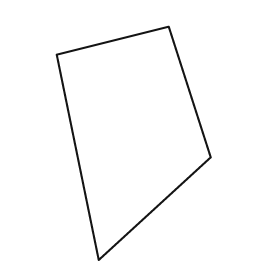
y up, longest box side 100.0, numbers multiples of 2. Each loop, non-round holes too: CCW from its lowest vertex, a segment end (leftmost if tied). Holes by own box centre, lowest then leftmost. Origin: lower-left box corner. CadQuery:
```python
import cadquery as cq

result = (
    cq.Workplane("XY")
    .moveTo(18.0, 0.0)
    .lineTo(66.0, 44.0)
    .lineTo(48.0, 100.0)
    .lineTo(0.0, 88.0)
    .close()
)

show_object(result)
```